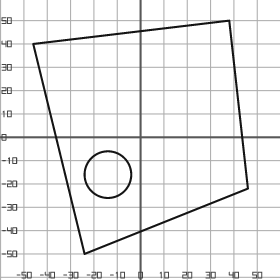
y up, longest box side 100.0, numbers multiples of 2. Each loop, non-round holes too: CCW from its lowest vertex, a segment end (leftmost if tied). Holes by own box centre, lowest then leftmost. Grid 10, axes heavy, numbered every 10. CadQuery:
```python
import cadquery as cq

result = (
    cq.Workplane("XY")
    .moveTo(-24.0, -50.0)
    .lineTo(46.0, -22.0)
    .lineTo(38.0, 50.0)
    .lineTo(-46.0, 40.0)
    .close()
    .moveTo(-14.0, -16.0)
    .circle(10.0)
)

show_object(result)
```